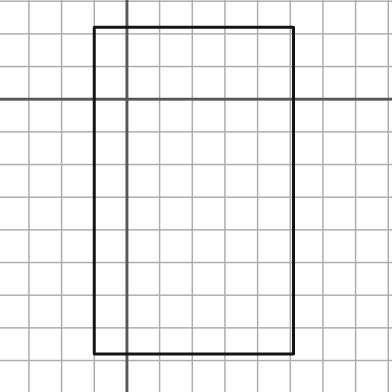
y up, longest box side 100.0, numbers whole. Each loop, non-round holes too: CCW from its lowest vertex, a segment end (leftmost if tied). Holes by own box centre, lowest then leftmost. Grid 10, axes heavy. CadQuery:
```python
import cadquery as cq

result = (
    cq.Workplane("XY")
    .moveTo(-10.0, -78.0)
    .lineTo(51.0, -78.0)
    .lineTo(51.0, 22.0)
    .lineTo(-10.0, 22.0)
    .close()
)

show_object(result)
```